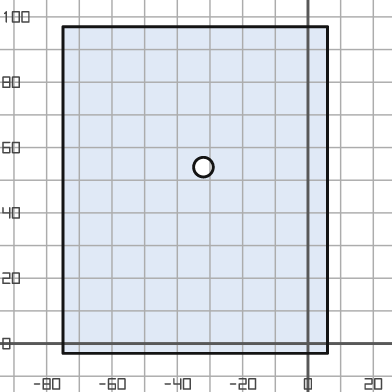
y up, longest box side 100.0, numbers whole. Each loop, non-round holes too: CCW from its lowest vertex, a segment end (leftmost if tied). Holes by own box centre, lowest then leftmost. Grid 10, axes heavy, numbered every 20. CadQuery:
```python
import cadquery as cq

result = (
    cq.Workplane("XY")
    .moveTo(-75.0, -3.0)
    .lineTo(6.0, -3.0)
    .lineTo(6.0, 97.0)
    .lineTo(-75.0, 97.0)
    .close()
    .moveTo(-32.0, 54.0)
    .circle(3.0)
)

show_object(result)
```